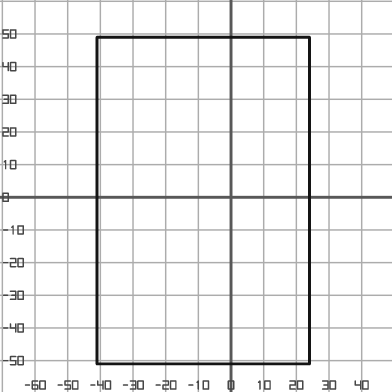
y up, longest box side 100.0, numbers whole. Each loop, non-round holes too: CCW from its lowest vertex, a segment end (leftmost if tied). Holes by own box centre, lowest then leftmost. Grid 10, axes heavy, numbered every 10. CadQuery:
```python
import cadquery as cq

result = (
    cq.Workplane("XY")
    .moveTo(-41.0, -51.0)
    .lineTo(24.0, -51.0)
    .lineTo(24.0, 49.0)
    .lineTo(-41.0, 49.0)
    .close()
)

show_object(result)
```